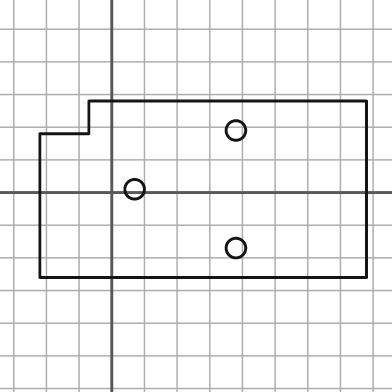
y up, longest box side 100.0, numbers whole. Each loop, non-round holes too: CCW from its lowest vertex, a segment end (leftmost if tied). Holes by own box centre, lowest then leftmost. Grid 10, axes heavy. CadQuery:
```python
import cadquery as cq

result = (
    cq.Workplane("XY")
    .moveTo(-22.0, -26.0)
    .lineTo(78.0, -26.0)
    .lineTo(78.0, 28.0)
    .lineTo(-7.0, 28.0)
    .lineTo(-7.0, 18.0)
    .lineTo(-22.0, 18.0)
    .close()
    .moveTo(38.0, -17.0)
    .circle(3.0)
    .moveTo(7.0, 1.0)
    .circle(3.0)
    .moveTo(38.0, 19.0)
    .circle(3.0)
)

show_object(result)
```